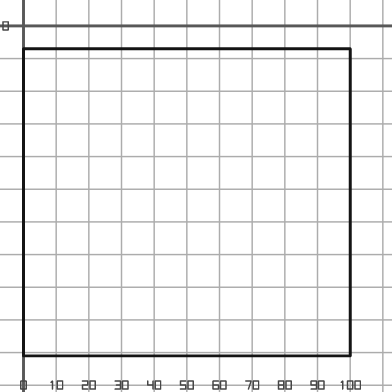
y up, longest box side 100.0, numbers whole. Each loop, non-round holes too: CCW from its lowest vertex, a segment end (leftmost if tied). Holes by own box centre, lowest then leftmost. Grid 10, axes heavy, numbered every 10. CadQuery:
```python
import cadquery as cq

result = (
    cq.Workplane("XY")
    .moveTo(0.0, -101.0)
    .lineTo(100.0, -101.0)
    .lineTo(100.0, -7.0)
    .lineTo(0.0, -7.0)
    .close()
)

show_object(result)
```